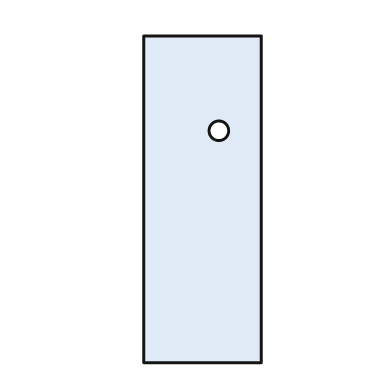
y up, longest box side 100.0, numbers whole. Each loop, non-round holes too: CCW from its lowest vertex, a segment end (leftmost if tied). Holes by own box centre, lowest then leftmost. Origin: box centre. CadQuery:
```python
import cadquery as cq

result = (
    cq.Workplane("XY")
    .moveTo(-18.0, -50.0)
    .lineTo(18.0, -50.0)
    .lineTo(18.0, 50.0)
    .lineTo(-18.0, 50.0)
    .close()
    .moveTo(5.0, 21.0)
    .circle(3.0)
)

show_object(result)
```